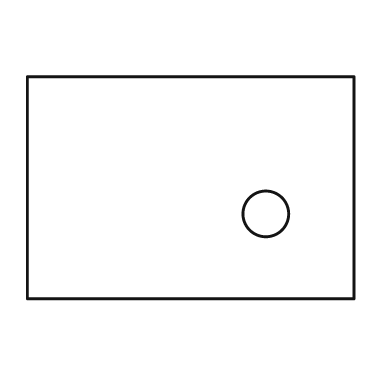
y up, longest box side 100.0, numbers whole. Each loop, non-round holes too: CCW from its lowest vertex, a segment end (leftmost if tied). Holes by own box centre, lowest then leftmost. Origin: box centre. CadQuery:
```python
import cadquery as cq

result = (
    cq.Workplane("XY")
    .moveTo(-50.0, -34.0)
    .lineTo(50.0, -34.0)
    .lineTo(50.0, 34.0)
    .lineTo(-50.0, 34.0)
    .close()
    .moveTo(23.0, -8.0)
    .circle(7.0)
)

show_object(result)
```